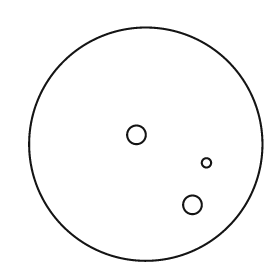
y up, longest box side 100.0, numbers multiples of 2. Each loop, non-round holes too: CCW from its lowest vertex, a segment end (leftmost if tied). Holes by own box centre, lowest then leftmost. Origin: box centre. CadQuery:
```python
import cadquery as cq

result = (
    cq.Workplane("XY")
    .moveTo(0.0, 0.0)
    .circle(50.0)
    .moveTo(20.0, -26.0)
    .circle(4.0)
    .moveTo(26.0, -8.0)
    .circle(2.0)
    .moveTo(-4.0, 4.0)
    .circle(4.0)
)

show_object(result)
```